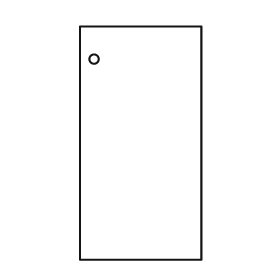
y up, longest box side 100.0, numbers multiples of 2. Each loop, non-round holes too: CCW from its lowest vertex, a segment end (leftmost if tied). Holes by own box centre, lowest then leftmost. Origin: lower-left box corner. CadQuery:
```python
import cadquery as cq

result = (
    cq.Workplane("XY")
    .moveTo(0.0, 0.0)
    .lineTo(52.0, 0.0)
    .lineTo(52.0, 100.0)
    .lineTo(0.0, 100.0)
    .close()
    .moveTo(6.0, 86.0)
    .circle(2.0)
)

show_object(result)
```